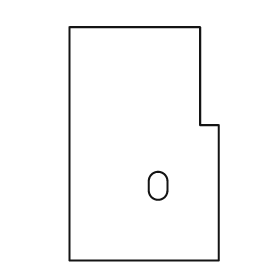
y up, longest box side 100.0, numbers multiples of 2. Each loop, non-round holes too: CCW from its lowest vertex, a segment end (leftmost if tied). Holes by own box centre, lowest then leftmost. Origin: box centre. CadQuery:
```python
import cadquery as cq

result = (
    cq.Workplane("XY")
    .moveTo(-32.0, -50.0)
    .lineTo(32.0, -50.0)
    .lineTo(32.0, 8.0)
    .lineTo(24.0, 8.0)
    .lineTo(24.0, 50.0)
    .lineTo(-32.0, 50.0)
    .close()
    .moveTo(2.0, -20.0)
    .threePointArc((6.0, -24.0), (10.0, -20.0))
    .lineTo(10.0, -16.0)
    .threePointArc((6.0, -12.0), (2.0, -16.0))
    .close()
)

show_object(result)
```